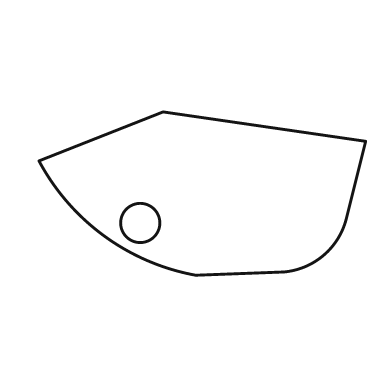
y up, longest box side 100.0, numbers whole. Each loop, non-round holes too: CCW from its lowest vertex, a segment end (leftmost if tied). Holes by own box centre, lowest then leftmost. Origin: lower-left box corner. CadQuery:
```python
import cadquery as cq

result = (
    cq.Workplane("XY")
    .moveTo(48.0, 0.0)
    .lineTo(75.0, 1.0)
    .threePointArc((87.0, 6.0), (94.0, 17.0))
    .lineTo(100.0, 41.0)
    .lineTo(38.0, 50.0)
    .lineTo(0.0, 35.0)
    .threePointArc((20.0, 12.0), (48.0, 0.0))
    .close()
    .moveTo(31.0, 16.0)
    .circle(6.0)
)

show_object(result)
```